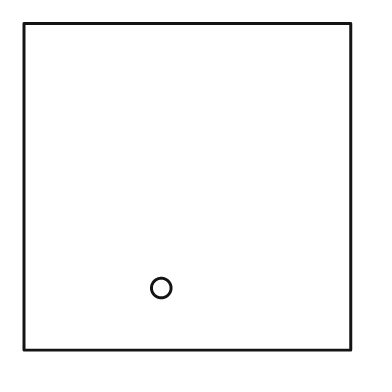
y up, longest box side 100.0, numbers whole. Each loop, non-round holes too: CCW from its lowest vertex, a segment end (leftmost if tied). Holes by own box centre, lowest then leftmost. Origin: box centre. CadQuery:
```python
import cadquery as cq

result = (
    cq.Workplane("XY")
    .moveTo(-50.0, -50.0)
    .lineTo(50.0, -50.0)
    .lineTo(50.0, 50.0)
    .lineTo(-50.0, 50.0)
    .close()
    .moveTo(-8.0, -31.0)
    .circle(3.0)
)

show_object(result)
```